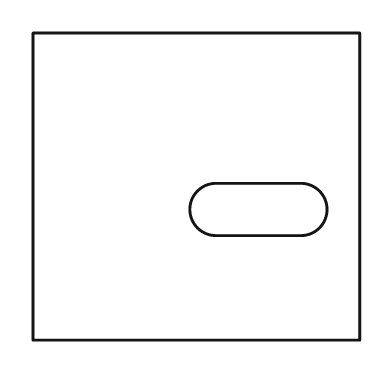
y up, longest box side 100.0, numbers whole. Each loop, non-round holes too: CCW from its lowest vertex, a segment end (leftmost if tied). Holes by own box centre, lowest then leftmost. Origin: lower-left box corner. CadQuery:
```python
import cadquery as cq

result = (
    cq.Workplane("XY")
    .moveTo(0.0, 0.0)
    .lineTo(100.0, 0.0)
    .lineTo(100.0, 94.0)
    .lineTo(0.0, 94.0)
    .close()
    .moveTo(56.0, 32.0)
    .lineTo(82.0, 32.0)
    .threePointArc((90.0, 40.0), (82.0, 48.0))
    .lineTo(56.0, 48.0)
    .threePointArc((48.0, 40.0), (56.0, 32.0))
    .close()
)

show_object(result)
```